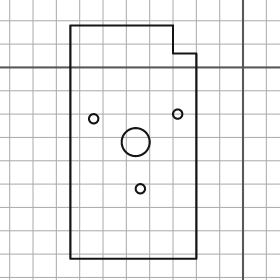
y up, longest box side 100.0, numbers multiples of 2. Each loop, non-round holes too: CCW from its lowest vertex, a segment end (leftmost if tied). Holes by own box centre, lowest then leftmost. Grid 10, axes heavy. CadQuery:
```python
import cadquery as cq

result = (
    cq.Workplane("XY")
    .moveTo(-74.0, -82.0)
    .lineTo(-20.0, -82.0)
    .lineTo(-20.0, 6.0)
    .lineTo(-30.0, 6.0)
    .lineTo(-30.0, 18.0)
    .lineTo(-74.0, 18.0)
    .close()
    .moveTo(-44.0, -52.0)
    .circle(2.0)
    .moveTo(-46.0, -32.0)
    .circle(6.0)
    .moveTo(-64.0, -22.0)
    .circle(2.0)
    .moveTo(-28.0, -20.0)
    .circle(2.0)
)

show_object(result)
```